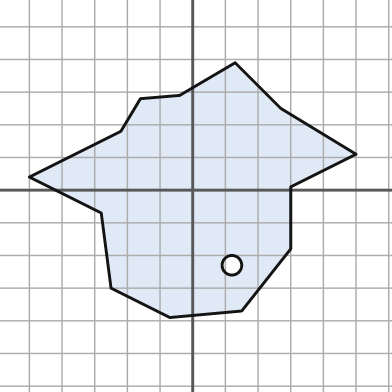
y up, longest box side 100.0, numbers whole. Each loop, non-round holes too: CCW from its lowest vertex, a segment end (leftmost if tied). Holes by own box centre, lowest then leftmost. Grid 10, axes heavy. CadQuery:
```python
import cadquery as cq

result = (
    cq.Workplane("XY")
    .moveTo(-7.0, -39.0)
    .lineTo(15.0, -37.0)
    .lineTo(30.0, -18.0)
    .lineTo(30.0, 1.0)
    .lineTo(50.0, 11.0)
    .lineTo(27.0, 25.0)
    .lineTo(13.0, 39.0)
    .lineTo(-4.0, 29.0)
    .lineTo(-16.0, 28.0)
    .lineTo(-22.0, 18.0)
    .lineTo(-50.0, 4.0)
    .lineTo(-28.0, -7.0)
    .lineTo(-25.0, -30.0)
    .close()
    .moveTo(12.0, -23.0)
    .circle(3.0)
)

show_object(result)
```